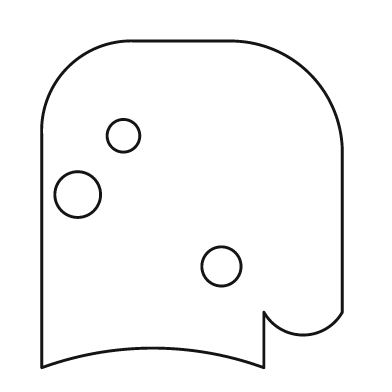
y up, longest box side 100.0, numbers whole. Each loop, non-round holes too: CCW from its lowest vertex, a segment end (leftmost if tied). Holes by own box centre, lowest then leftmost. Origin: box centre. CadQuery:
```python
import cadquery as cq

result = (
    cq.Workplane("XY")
    .moveTo(-46.0, -50.0)
    .threePointArc((-12.0, -44.0), (22.0, -50.0))
    .lineTo(22.0, -33.0)
    .threePointArc((34.0, -40.0), (46.0, -33.0))
    .lineTo(46.0, 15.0)
    .threePointArc((36.0, 40.0), (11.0, 50.0))
    .lineTo(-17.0, 50.0)
    .threePointArc((-38.0, 42.0), (-46.0, 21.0))
    .close()
    .moveTo(9.0, -19.0)
    .circle(6.0)
    .moveTo(-35.0, 3.0)
    .circle(7.0)
    .moveTo(-21.0, 21.0)
    .circle(5.0)
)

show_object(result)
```